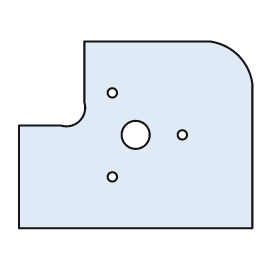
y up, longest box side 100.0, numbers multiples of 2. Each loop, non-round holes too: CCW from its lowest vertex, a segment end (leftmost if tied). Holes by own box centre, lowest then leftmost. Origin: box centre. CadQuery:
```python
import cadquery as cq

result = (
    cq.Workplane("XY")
    .moveTo(-50.0, -40.0)
    .lineTo(50.0, -40.0)
    .lineTo(50.0, 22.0)
    .threePointArc((44.0, 34.0), (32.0, 40.0))
    .lineTo(-22.0, 40.0)
    .lineTo(-22.0, 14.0)
    .threePointArc((-24.0, 6.0), (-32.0, 4.0))
    .lineTo(-50.0, 4.0)
    .close()
    .moveTo(-10.0, -18.0)
    .circle(2.0)
    .moveTo(0.0, 0.0)
    .circle(6.0)
    .moveTo(20.0, 0.0)
    .circle(2.0)
    .moveTo(-10.0, 18.0)
    .circle(2.0)
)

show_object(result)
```